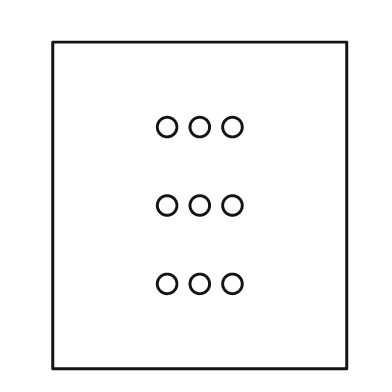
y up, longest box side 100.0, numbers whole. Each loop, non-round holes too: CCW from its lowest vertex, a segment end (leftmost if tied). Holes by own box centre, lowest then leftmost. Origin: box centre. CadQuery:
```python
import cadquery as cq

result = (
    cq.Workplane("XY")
    .moveTo(-45.0, -50.0)
    .lineTo(45.0, -50.0)
    .lineTo(45.0, 50.0)
    .lineTo(-45.0, 50.0)
    .close()
    .moveTo(-10.0, -24.0)
    .circle(3.0)
    .moveTo(0.0, -24.0)
    .circle(3.0)
    .moveTo(10.0, -24.0)
    .circle(3.0)
    .moveTo(-10.0, 0.0)
    .circle(3.0)
    .moveTo(0.0, 0.0)
    .circle(3.0)
    .moveTo(10.0, 0.0)
    .circle(3.0)
    .moveTo(-10.0, 24.0)
    .circle(3.0)
    .moveTo(0.0, 24.0)
    .circle(3.0)
    .moveTo(10.0, 24.0)
    .circle(3.0)
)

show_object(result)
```